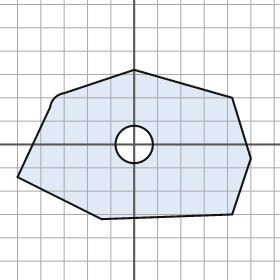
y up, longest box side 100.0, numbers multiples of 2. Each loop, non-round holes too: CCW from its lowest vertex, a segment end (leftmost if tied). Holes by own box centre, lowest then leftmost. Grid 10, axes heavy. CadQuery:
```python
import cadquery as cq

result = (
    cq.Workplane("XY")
    .moveTo(-14.0, -32.0)
    .lineTo(42.0, -30.0)
    .lineTo(50.0, -6.0)
    .lineTo(42.0, 20.0)
    .lineTo(0.0, 32.0)
    .lineTo(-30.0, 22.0)
    .threePointArc((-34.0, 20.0), (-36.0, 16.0))
    .lineTo(-50.0, -14.0)
    .close()
    .moveTo(0.0, 0.0)
    .circle(8.0)
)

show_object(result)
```